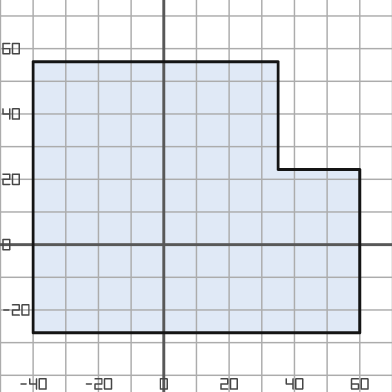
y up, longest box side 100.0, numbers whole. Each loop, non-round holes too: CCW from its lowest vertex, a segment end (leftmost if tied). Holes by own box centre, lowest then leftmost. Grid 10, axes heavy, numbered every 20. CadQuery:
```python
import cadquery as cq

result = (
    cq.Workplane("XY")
    .moveTo(-40.0, -27.0)
    .lineTo(60.0, -27.0)
    .lineTo(60.0, 23.0)
    .lineTo(35.0, 23.0)
    .lineTo(35.0, 56.0)
    .lineTo(-40.0, 56.0)
    .close()
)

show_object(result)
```